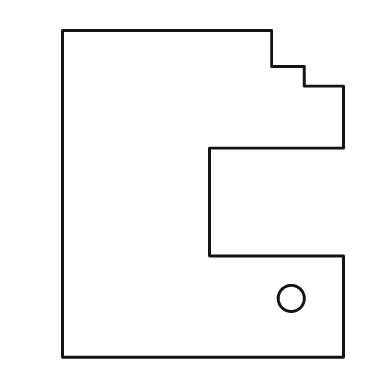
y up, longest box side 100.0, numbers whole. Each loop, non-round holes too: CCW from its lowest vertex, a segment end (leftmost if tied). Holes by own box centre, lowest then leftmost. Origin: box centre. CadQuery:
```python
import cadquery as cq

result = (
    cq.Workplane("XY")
    .moveTo(-43.0, -50.0)
    .lineTo(43.0, -50.0)
    .lineTo(43.0, -19.0)
    .lineTo(2.0, -19.0)
    .lineTo(2.0, 14.0)
    .lineTo(43.0, 14.0)
    .lineTo(43.0, 33.0)
    .lineTo(31.0, 33.0)
    .lineTo(31.0, 39.0)
    .lineTo(21.0, 39.0)
    .lineTo(21.0, 50.0)
    .lineTo(-43.0, 50.0)
    .close()
    .moveTo(27.0, -32.0)
    .circle(4.0)
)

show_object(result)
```